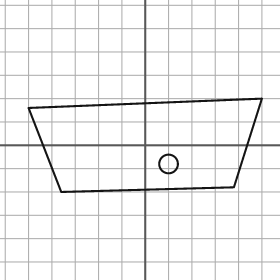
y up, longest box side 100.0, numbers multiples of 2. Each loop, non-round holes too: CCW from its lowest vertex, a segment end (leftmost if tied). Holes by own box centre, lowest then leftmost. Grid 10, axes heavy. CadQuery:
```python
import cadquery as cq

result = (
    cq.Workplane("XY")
    .moveTo(-36.0, -20.0)
    .lineTo(38.0, -18.0)
    .lineTo(50.0, 20.0)
    .lineTo(-50.0, 16.0)
    .close()
    .moveTo(10.0, -8.0)
    .circle(4.0)
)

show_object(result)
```